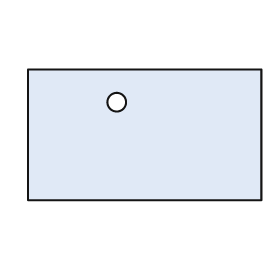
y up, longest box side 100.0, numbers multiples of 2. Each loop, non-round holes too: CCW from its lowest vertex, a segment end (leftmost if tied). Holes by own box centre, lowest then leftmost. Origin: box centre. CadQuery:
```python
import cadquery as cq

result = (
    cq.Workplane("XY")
    .moveTo(-50.0, -28.0)
    .lineTo(50.0, -28.0)
    .lineTo(50.0, 28.0)
    .lineTo(-50.0, 28.0)
    .close()
    .moveTo(-12.0, 14.0)
    .circle(4.0)
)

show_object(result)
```